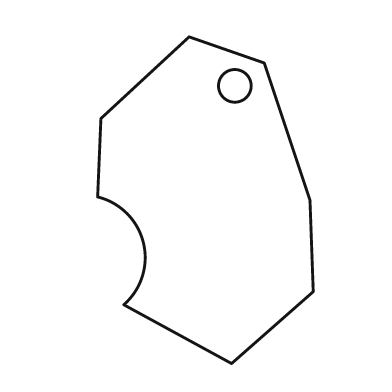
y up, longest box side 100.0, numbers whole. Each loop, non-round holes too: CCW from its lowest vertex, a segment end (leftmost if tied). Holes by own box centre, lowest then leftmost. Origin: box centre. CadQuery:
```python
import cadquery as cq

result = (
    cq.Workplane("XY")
    .moveTo(8.0, -50.0)
    .lineTo(33.0, -28.0)
    .lineTo(32.0, 0.0)
    .lineTo(18.0, 42.0)
    .lineTo(-5.0, 50.0)
    .lineTo(-32.0, 25.0)
    .lineTo(-33.0, 1.0)
    .threePointArc((-19.0, -13.0), (-25.0, -32.0))
    .close()
    .moveTo(9.0, 35.0)
    .circle(5.0)
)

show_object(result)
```